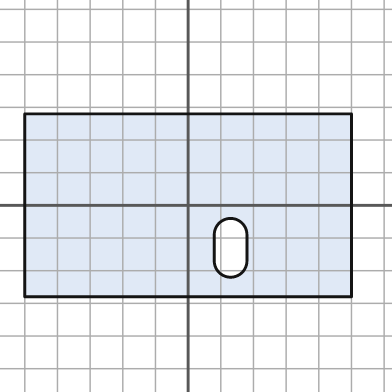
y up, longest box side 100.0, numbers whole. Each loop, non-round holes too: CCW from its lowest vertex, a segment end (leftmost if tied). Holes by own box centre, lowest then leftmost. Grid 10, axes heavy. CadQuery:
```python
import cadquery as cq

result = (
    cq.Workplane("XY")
    .moveTo(-50.0, -28.0)
    .lineTo(50.0, -28.0)
    .lineTo(50.0, 28.0)
    .lineTo(-50.0, 28.0)
    .close()
    .moveTo(8.0, -17.0)
    .threePointArc((13.0, -22.0), (18.0, -17.0))
    .lineTo(18.0, -9.0)
    .threePointArc((13.0, -4.0), (8.0, -9.0))
    .close()
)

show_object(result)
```